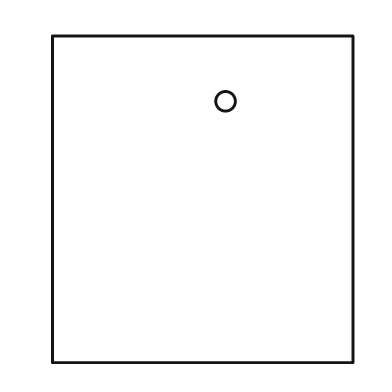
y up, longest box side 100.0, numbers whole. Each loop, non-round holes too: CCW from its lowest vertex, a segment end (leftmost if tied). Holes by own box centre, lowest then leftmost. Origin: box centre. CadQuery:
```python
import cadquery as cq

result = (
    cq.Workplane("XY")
    .moveTo(-46.0, -50.0)
    .lineTo(46.0, -50.0)
    .lineTo(46.0, 50.0)
    .lineTo(-46.0, 50.0)
    .close()
    .moveTo(7.0, 30.0)
    .circle(3.0)
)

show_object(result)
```